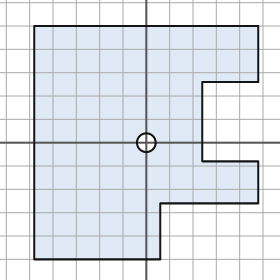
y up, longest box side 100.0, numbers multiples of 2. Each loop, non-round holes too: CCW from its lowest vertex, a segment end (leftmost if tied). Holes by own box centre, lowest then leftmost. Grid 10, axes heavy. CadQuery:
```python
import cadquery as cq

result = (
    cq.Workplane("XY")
    .moveTo(-48.0, -50.0)
    .lineTo(6.0, -50.0)
    .lineTo(6.0, -26.0)
    .lineTo(48.0, -26.0)
    .lineTo(48.0, -8.0)
    .lineTo(24.0, -8.0)
    .lineTo(24.0, 26.0)
    .lineTo(48.0, 26.0)
    .lineTo(48.0, 50.0)
    .lineTo(-48.0, 50.0)
    .close()
    .moveTo(0.0, 0.0)
    .circle(4.0)
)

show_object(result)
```